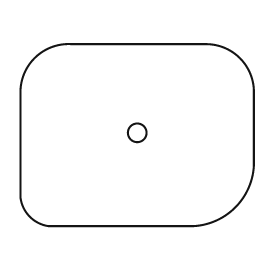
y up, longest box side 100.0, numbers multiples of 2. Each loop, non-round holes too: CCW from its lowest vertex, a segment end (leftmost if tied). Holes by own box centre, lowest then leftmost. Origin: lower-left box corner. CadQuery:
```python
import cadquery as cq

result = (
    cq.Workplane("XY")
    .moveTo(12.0, 0.0)
    .lineTo(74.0, 0.0)
    .threePointArc((92.0, 8.0), (100.0, 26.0))
    .lineTo(100.0, 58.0)
    .threePointArc((94.0, 72.0), (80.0, 78.0))
    .lineTo(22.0, 78.0)
    .threePointArc((6.0, 72.0), (0.0, 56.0))
    .lineTo(0.0, 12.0)
    .threePointArc((4.0, 4.0), (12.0, 0.0))
    .close()
    .moveTo(50.0, 40.0)
    .circle(4.0)
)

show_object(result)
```